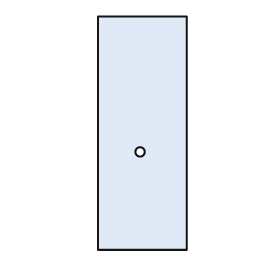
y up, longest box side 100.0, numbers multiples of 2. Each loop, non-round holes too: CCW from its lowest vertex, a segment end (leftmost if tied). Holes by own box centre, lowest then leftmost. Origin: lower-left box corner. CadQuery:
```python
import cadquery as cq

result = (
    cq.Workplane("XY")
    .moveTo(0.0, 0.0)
    .lineTo(38.0, 0.0)
    .lineTo(38.0, 100.0)
    .lineTo(0.0, 100.0)
    .close()
    .moveTo(18.0, 42.0)
    .circle(2.0)
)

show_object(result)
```